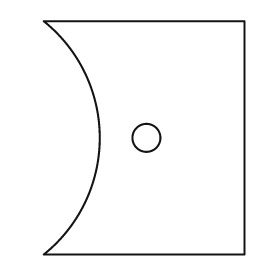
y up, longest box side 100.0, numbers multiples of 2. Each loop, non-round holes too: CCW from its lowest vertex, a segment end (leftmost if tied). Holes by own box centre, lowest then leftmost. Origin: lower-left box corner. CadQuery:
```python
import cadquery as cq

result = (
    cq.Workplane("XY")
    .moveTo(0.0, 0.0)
    .lineTo(86.0, 0.0)
    .lineTo(86.0, 100.0)
    .lineTo(0.0, 100.0)
    .threePointArc((24.0, 50.0), (0.0, 0.0))
    .close()
    .moveTo(44.0, 50.0)
    .circle(6.0)
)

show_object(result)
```